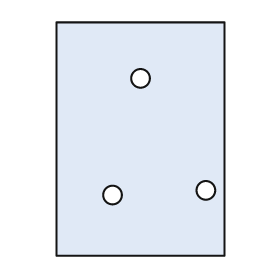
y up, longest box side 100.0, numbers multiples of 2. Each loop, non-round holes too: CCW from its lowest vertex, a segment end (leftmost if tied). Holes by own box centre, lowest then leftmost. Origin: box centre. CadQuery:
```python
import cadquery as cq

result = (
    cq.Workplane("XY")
    .moveTo(-36.0, -50.0)
    .lineTo(36.0, -50.0)
    .lineTo(36.0, 50.0)
    .lineTo(-36.0, 50.0)
    .close()
    .moveTo(-12.0, -24.0)
    .circle(4.0)
    .moveTo(28.0, -22.0)
    .circle(4.0)
    .moveTo(0.0, 26.0)
    .circle(4.0)
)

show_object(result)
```